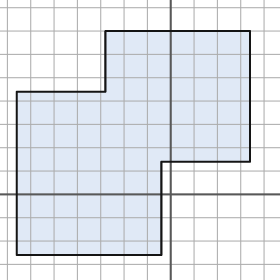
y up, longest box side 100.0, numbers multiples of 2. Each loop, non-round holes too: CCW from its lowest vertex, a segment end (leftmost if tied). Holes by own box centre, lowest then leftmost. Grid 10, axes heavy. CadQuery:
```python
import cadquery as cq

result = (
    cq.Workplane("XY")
    .moveTo(-66.0, -26.0)
    .lineTo(-4.0, -26.0)
    .lineTo(-4.0, 14.0)
    .lineTo(34.0, 14.0)
    .lineTo(34.0, 70.0)
    .lineTo(-28.0, 70.0)
    .lineTo(-28.0, 44.0)
    .lineTo(-66.0, 44.0)
    .close()
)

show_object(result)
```